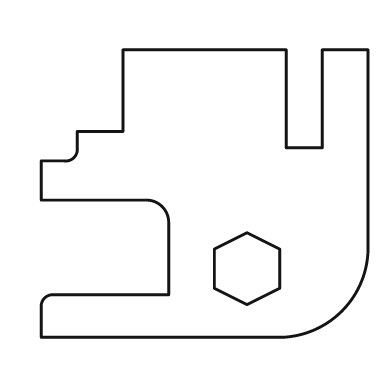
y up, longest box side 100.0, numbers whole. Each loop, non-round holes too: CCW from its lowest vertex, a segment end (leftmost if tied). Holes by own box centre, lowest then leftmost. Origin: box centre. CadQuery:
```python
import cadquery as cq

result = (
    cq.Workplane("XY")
    .moveTo(-50.0, -44.0)
    .lineTo(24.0, -44.0)
    .threePointArc((42.0, -36.0), (50.0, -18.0))
    .lineTo(50.0, 44.0)
    .lineTo(36.0, 44.0)
    .lineTo(36.0, 14.0)
    .lineTo(25.0, 14.0)
    .lineTo(25.0, 44.0)
    .lineTo(-25.0, 44.0)
    .lineTo(-25.0, 19.0)
    .lineTo(-39.0, 19.0)
    .lineTo(-39.0, 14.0)
    .threePointArc((-40.0, 11.0), (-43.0, 10.0))
    .lineTo(-50.0, 10.0)
    .lineTo(-50.0, -2.0)
    .lineTo(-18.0, -2.0)
    .threePointArc((-13.0, -4.0), (-11.0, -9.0))
    .lineTo(-11.0, -31.0)
    .lineTo(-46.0, -31.0)
    .threePointArc((-49.0, -32.0), (-50.0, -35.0))
    .close()
    .moveTo(13.0, -34.0)
    .lineTo(23.0, -29.0)
    .lineTo(23.0, -17.0)
    .lineTo(13.0, -12.0)
    .lineTo(3.0, -17.0)
    .lineTo(3.0, -29.0)
    .close()
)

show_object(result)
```